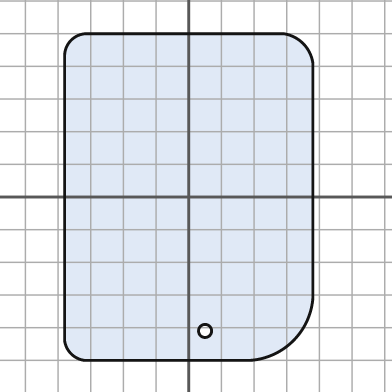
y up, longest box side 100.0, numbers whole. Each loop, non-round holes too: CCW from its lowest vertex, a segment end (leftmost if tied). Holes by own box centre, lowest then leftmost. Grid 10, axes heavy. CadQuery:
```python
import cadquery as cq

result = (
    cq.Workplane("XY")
    .moveTo(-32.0, -50.0)
    .lineTo(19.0, -50.0)
    .threePointArc((32.0, -44.0), (38.0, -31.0))
    .lineTo(38.0, 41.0)
    .threePointArc((35.0, 47.0), (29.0, 50.0))
    .lineTo(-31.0, 50.0)
    .threePointArc((-36.0, 48.0), (-38.0, 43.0))
    .lineTo(-38.0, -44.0)
    .threePointArc((-36.0, -48.0), (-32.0, -50.0))
    .close()
    .moveTo(5.0, -41.0)
    .circle(2.0)
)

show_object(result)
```